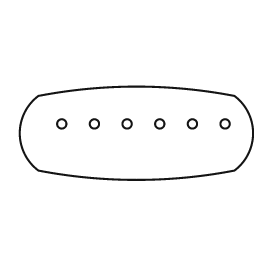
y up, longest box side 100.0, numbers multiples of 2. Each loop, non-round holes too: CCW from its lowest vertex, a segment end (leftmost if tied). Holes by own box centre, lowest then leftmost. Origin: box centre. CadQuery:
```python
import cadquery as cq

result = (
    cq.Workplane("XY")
    .moveTo(-42.0, -16.0)
    .threePointArc((0.0, -20.0), (42.0, -16.0))
    .threePointArc((50.0, 0.0), (42.0, 16.0))
    .threePointArc((0.0, 20.0), (-42.0, 16.0))
    .threePointArc((-50.0, 0.0), (-42.0, -16.0))
    .close()
    .moveTo(-32.0, 4.0)
    .circle(2.0)
    .moveTo(-18.0, 4.0)
    .circle(2.0)
    .moveTo(-4.0, 4.0)
    .circle(2.0)
    .moveTo(10.0, 4.0)
    .circle(2.0)
    .moveTo(24.0, 4.0)
    .circle(2.0)
    .moveTo(38.0, 4.0)
    .circle(2.0)
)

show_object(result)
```